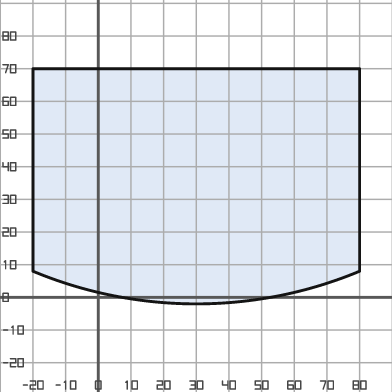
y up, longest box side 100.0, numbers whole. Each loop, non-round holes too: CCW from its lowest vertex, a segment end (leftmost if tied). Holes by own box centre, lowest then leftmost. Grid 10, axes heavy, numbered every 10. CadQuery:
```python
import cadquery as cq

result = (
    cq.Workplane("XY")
    .moveTo(-20.0, 8.0)
    .threePointArc((30.0, -2.0), (80.0, 8.0))
    .lineTo(80.0, 70.0)
    .lineTo(-20.0, 70.0)
    .close()
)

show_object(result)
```